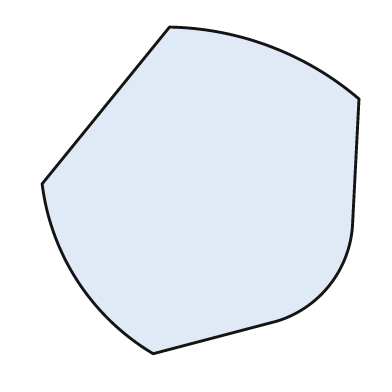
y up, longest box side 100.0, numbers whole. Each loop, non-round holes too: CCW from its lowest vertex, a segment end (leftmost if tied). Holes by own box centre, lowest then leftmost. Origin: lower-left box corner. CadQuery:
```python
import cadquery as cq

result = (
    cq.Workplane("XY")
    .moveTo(34.0, 0.0)
    .lineTo(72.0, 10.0)
    .threePointArc((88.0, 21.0), (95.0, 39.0))
    .lineTo(97.0, 78.0)
    .threePointArc((70.0, 94.0), (39.0, 100.0))
    .lineTo(0.0, 52.0)
    .threePointArc((11.0, 22.0), (34.0, 0.0))
    .close()
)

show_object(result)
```